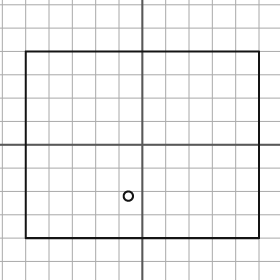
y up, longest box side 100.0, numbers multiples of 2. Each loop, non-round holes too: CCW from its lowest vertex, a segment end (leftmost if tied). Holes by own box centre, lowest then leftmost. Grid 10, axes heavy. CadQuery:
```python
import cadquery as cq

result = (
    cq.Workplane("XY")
    .moveTo(-50.0, -40.0)
    .lineTo(50.0, -40.0)
    .lineTo(50.0, 40.0)
    .lineTo(-50.0, 40.0)
    .close()
    .moveTo(-6.0, -22.0)
    .circle(2.0)
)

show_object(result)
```